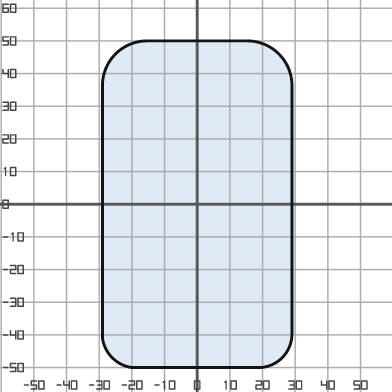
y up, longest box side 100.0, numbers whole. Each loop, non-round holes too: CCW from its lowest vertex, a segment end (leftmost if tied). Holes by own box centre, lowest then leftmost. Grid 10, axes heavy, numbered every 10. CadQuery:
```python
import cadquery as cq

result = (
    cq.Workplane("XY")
    .moveTo(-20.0, -50.0)
    .lineTo(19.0, -50.0)
    .threePointArc((26.0, -47.0), (29.0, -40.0))
    .lineTo(29.0, 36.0)
    .threePointArc((25.0, 46.0), (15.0, 50.0))
    .lineTo(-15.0, 50.0)
    .threePointArc((-25.0, 46.0), (-29.0, 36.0))
    .lineTo(-29.0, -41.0)
    .threePointArc((-26.0, -47.0), (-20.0, -50.0))
    .close()
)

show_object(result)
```